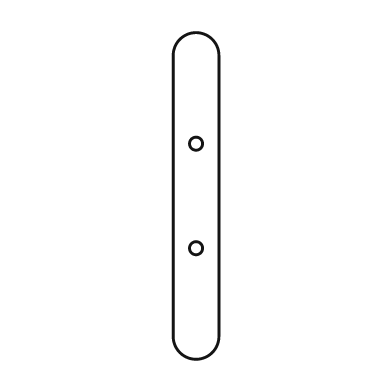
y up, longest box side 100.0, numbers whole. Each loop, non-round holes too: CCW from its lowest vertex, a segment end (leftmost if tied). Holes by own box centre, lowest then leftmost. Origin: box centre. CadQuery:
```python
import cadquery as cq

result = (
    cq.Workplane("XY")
    .moveTo(-7.0, -43.0)
    .threePointArc((0.0, -50.0), (7.0, -43.0))
    .lineTo(7.0, 43.0)
    .threePointArc((0.0, 50.0), (-7.0, 43.0))
    .close()
    .moveTo(0.0, -16.0)
    .circle(2.0)
    .moveTo(0.0, 16.0)
    .circle(2.0)
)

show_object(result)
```